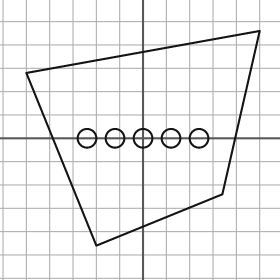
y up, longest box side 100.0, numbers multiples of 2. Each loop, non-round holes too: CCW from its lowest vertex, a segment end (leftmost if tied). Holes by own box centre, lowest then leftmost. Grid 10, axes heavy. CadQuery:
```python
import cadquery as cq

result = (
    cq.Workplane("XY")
    .moveTo(-20.0, -46.0)
    .lineTo(34.0, -24.0)
    .lineTo(50.0, 46.0)
    .lineTo(-50.0, 28.0)
    .close()
    .moveTo(-24.0, 0.0)
    .circle(4.0)
    .moveTo(-12.0, 0.0)
    .circle(4.0)
    .moveTo(0.0, 0.0)
    .circle(4.0)
    .moveTo(12.0, 0.0)
    .circle(4.0)
    .moveTo(24.0, 0.0)
    .circle(4.0)
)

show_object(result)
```